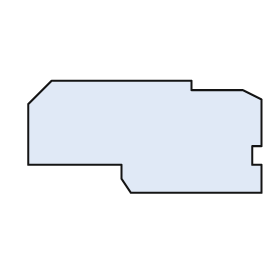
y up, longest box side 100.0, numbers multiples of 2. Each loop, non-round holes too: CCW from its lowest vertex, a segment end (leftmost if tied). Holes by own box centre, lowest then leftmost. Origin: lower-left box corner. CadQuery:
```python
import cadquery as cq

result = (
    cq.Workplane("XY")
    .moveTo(44.0, 0.0)
    .lineTo(100.0, 0.0)
    .lineTo(100.0, 12.0)
    .lineTo(96.0, 12.0)
    .lineTo(96.0, 20.0)
    .lineTo(100.0, 20.0)
    .lineTo(100.0, 40.0)
    .lineTo(92.0, 44.0)
    .lineTo(70.0, 44.0)
    .lineTo(70.0, 48.0)
    .lineTo(10.0, 48.0)
    .lineTo(0.0, 38.0)
    .lineTo(0.0, 12.0)
    .lineTo(40.0, 12.0)
    .lineTo(40.0, 6.0)
    .close()
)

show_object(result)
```